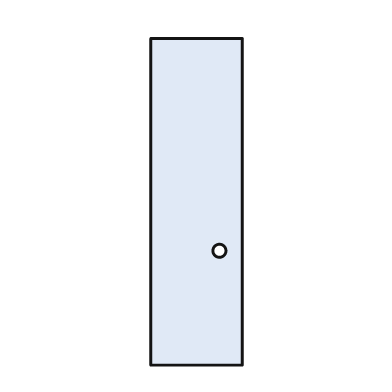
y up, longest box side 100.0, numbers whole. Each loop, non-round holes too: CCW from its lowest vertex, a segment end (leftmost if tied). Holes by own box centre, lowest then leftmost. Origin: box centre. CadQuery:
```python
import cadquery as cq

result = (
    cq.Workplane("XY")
    .moveTo(-14.0, -50.0)
    .lineTo(14.0, -50.0)
    .lineTo(14.0, 50.0)
    .lineTo(-14.0, 50.0)
    .close()
    .moveTo(7.0, -15.0)
    .circle(2.0)
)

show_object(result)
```